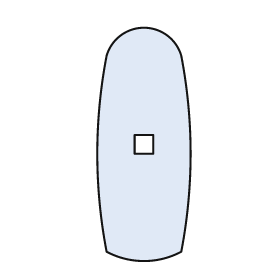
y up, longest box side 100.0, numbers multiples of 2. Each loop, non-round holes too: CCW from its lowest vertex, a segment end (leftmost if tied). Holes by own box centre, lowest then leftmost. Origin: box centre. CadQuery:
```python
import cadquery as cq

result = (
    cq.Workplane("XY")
    .moveTo(-16.0, -46.0)
    .threePointArc((0.0, -50.0), (16.0, -46.0))
    .threePointArc((20.0, -4.0), (16.0, 38.0))
    .threePointArc((0.0, 50.0), (-16.0, 38.0))
    .threePointArc((-20.0, -4.0), (-16.0, -46.0))
    .close()
    .moveTo(-4.0, -4.0)
    .lineTo(4.0, -4.0)
    .lineTo(4.0, 4.0)
    .lineTo(-4.0, 4.0)
    .close()
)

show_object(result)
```